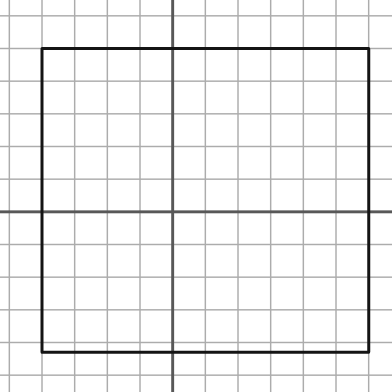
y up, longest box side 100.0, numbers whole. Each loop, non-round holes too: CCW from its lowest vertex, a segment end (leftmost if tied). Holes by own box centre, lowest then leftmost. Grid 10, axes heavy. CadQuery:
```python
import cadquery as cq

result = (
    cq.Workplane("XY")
    .moveTo(-40.0, -43.0)
    .lineTo(60.0, -43.0)
    .lineTo(60.0, 50.0)
    .lineTo(-40.0, 50.0)
    .close()
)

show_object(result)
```